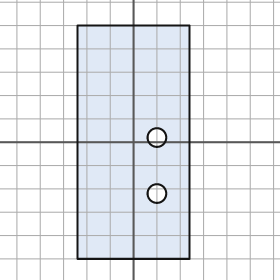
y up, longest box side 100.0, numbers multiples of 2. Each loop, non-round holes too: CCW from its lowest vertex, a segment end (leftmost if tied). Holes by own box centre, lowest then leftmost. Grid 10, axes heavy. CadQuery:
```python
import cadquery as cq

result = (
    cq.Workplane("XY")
    .moveTo(-24.0, -50.0)
    .lineTo(24.0, -50.0)
    .lineTo(24.0, 50.0)
    .lineTo(-24.0, 50.0)
    .close()
    .moveTo(10.0, -22.0)
    .circle(4.0)
    .moveTo(10.0, 2.0)
    .circle(4.0)
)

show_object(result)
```